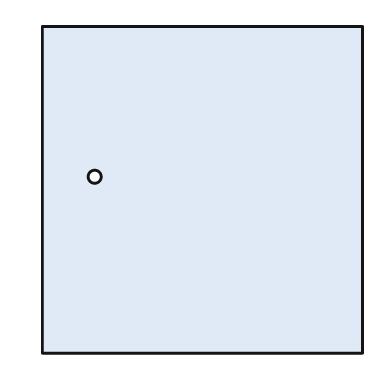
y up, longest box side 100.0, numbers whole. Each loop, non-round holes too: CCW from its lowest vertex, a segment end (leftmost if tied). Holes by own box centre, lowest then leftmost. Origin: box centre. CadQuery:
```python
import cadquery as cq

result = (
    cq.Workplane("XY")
    .moveTo(-49.0, -50.0)
    .lineTo(49.0, -50.0)
    .lineTo(49.0, 50.0)
    .lineTo(-49.0, 50.0)
    .close()
    .moveTo(-33.0, 4.0)
    .circle(2.0)
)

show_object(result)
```